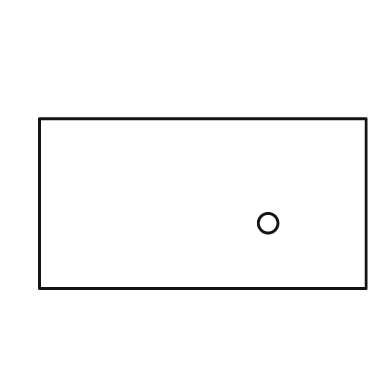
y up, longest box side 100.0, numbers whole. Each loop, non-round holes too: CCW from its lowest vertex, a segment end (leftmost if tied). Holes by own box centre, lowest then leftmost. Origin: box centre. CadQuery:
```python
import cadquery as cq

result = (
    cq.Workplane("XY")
    .moveTo(-50.0, -26.0)
    .lineTo(50.0, -26.0)
    .lineTo(50.0, 26.0)
    .lineTo(-50.0, 26.0)
    .close()
    .moveTo(20.0, -6.0)
    .circle(3.0)
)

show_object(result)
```